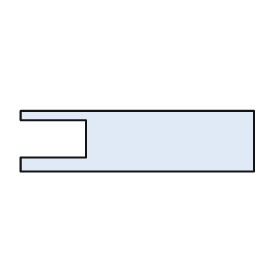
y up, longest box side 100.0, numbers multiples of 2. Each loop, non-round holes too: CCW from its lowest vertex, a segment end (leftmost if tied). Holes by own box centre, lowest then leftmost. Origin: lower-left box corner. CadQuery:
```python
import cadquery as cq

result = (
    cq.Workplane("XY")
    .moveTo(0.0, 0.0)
    .lineTo(100.0, 0.0)
    .lineTo(100.0, 26.0)
    .lineTo(0.0, 26.0)
    .lineTo(0.0, 22.0)
    .lineTo(28.0, 22.0)
    .lineTo(28.0, 6.0)
    .lineTo(0.0, 6.0)
    .close()
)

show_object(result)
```